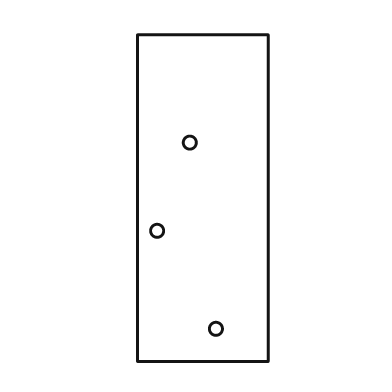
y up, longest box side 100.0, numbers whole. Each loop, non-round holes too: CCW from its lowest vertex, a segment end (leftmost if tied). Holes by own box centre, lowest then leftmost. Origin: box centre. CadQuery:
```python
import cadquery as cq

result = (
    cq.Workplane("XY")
    .moveTo(-20.0, -50.0)
    .lineTo(20.0, -50.0)
    .lineTo(20.0, 50.0)
    .lineTo(-20.0, 50.0)
    .close()
    .moveTo(4.0, -40.0)
    .circle(2.0)
    .moveTo(-14.0, -10.0)
    .circle(2.0)
    .moveTo(-4.0, 17.0)
    .circle(2.0)
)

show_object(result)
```